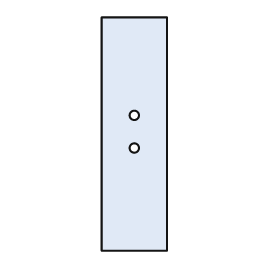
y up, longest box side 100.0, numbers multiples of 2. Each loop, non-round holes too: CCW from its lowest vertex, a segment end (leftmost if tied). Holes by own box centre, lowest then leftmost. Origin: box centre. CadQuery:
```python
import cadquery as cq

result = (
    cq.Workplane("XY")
    .moveTo(-14.0, -50.0)
    .lineTo(14.0, -50.0)
    .lineTo(14.0, 50.0)
    .lineTo(-14.0, 50.0)
    .close()
    .moveTo(0.0, -6.0)
    .circle(2.0)
    .moveTo(0.0, 8.0)
    .circle(2.0)
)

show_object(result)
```